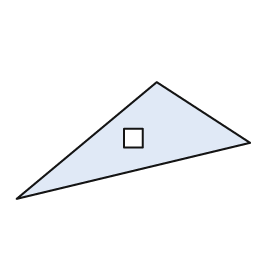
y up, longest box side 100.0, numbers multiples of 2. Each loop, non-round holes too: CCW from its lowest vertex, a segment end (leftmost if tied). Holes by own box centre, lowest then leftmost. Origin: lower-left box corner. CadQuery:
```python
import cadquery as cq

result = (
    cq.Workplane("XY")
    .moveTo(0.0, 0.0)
    .lineTo(100.0, 24.0)
    .lineTo(60.0, 50.0)
    .close()
    .moveTo(46.0, 22.0)
    .lineTo(54.0, 22.0)
    .lineTo(54.0, 30.0)
    .lineTo(46.0, 30.0)
    .close()
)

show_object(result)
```